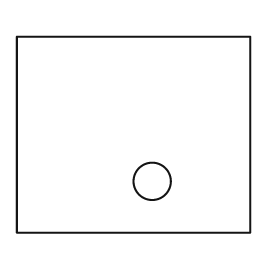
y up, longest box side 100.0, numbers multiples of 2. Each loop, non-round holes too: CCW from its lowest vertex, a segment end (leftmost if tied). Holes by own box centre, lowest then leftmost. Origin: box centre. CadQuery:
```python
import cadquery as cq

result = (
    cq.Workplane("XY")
    .moveTo(-50.0, -42.0)
    .lineTo(50.0, -42.0)
    .lineTo(50.0, 42.0)
    .lineTo(-50.0, 42.0)
    .close()
    .moveTo(8.0, -20.0)
    .circle(8.0)
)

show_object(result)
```